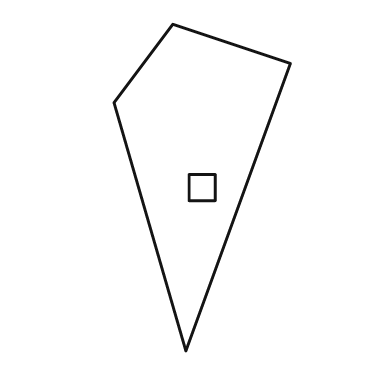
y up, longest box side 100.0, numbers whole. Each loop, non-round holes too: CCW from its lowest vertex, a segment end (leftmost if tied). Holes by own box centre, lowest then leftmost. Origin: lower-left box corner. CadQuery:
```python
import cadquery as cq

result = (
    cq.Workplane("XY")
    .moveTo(22.0, 0.0)
    .lineTo(54.0, 88.0)
    .lineTo(18.0, 100.0)
    .lineTo(0.0, 76.0)
    .close()
    .moveTo(23.0, 46.0)
    .lineTo(31.0, 46.0)
    .lineTo(31.0, 54.0)
    .lineTo(23.0, 54.0)
    .close()
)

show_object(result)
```